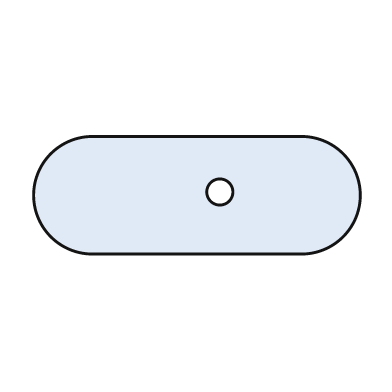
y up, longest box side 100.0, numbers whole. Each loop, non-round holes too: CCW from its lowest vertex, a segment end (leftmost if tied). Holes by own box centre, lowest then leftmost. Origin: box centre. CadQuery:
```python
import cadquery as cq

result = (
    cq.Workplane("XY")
    .moveTo(-32.0, -18.0)
    .lineTo(32.0, -18.0)
    .threePointArc((50.0, 0.0), (32.0, 18.0))
    .lineTo(-32.0, 18.0)
    .threePointArc((-50.0, 0.0), (-32.0, -18.0))
    .close()
    .moveTo(7.0, 1.0)
    .circle(4.0)
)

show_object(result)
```